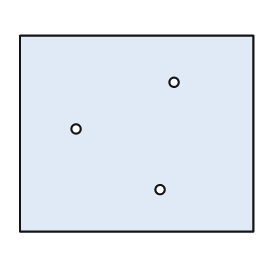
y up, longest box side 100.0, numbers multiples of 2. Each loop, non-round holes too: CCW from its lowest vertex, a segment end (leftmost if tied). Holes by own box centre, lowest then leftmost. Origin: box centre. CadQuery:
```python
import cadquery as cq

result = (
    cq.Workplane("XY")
    .moveTo(-50.0, -42.0)
    .lineTo(50.0, -42.0)
    .lineTo(50.0, 42.0)
    .lineTo(-50.0, 42.0)
    .close()
    .moveTo(10.0, -24.0)
    .circle(2.0)
    .moveTo(-26.0, 2.0)
    .circle(2.0)
    .moveTo(16.0, 22.0)
    .circle(2.0)
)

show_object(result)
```